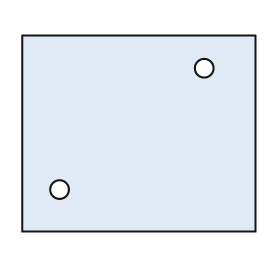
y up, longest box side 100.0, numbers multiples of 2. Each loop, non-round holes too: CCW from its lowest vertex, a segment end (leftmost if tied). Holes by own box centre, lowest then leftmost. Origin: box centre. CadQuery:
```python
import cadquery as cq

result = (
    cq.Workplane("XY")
    .moveTo(-50.0, -42.0)
    .lineTo(50.0, -42.0)
    .lineTo(50.0, 42.0)
    .lineTo(-50.0, 42.0)
    .close()
    .moveTo(-34.0, -24.0)
    .circle(4.0)
    .moveTo(28.0, 28.0)
    .circle(4.0)
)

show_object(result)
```